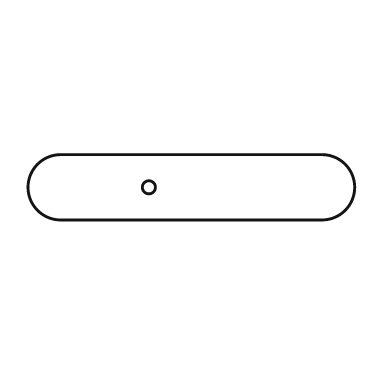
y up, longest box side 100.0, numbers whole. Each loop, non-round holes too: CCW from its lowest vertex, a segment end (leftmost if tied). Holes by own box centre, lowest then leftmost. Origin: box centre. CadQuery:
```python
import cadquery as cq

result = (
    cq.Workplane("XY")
    .moveTo(-40.0, -10.0)
    .lineTo(40.0, -10.0)
    .threePointArc((50.0, 0.0), (40.0, 10.0))
    .lineTo(-40.0, 10.0)
    .threePointArc((-50.0, 0.0), (-40.0, -10.0))
    .close()
    .moveTo(-13.0, 0.0)
    .circle(2.0)
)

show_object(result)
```